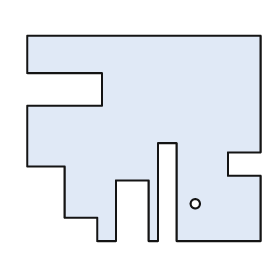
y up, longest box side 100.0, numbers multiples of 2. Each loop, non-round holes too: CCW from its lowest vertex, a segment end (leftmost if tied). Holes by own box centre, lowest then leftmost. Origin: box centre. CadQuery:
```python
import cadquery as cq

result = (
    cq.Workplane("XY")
    .moveTo(-20.0, -44.0)
    .lineTo(-12.0, -44.0)
    .lineTo(-12.0, -18.0)
    .lineTo(2.0, -18.0)
    .lineTo(2.0, -44.0)
    .lineTo(6.0, -44.0)
    .lineTo(6.0, -2.0)
    .lineTo(14.0, -2.0)
    .lineTo(14.0, -44.0)
    .lineTo(50.0, -44.0)
    .lineTo(50.0, -16.0)
    .lineTo(36.0, -16.0)
    .lineTo(36.0, -6.0)
    .lineTo(50.0, -6.0)
    .lineTo(50.0, 44.0)
    .lineTo(-50.0, 44.0)
    .lineTo(-50.0, 28.0)
    .lineTo(-18.0, 28.0)
    .lineTo(-18.0, 14.0)
    .lineTo(-50.0, 14.0)
    .lineTo(-50.0, -12.0)
    .lineTo(-34.0, -12.0)
    .lineTo(-34.0, -34.0)
    .lineTo(-20.0, -34.0)
    .close()
    .moveTo(22.0, -28.0)
    .circle(2.0)
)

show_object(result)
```